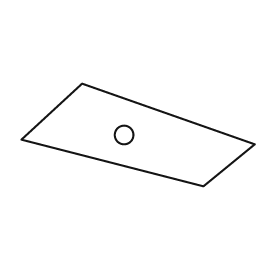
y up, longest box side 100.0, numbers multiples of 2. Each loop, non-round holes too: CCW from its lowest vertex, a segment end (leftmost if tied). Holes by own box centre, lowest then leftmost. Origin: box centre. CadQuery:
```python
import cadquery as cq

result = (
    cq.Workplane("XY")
    .moveTo(28.0, -22.0)
    .lineTo(50.0, -4.0)
    .lineTo(-24.0, 22.0)
    .lineTo(-50.0, -2.0)
    .close()
    .moveTo(-6.0, 0.0)
    .circle(4.0)
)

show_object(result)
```